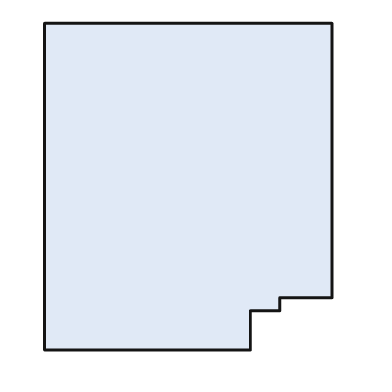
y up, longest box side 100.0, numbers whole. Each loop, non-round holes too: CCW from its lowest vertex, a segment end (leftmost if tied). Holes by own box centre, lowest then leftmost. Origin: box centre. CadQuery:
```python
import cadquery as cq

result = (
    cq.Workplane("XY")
    .moveTo(-44.0, -50.0)
    .lineTo(19.0, -50.0)
    .lineTo(19.0, -38.0)
    .lineTo(28.0, -38.0)
    .lineTo(28.0, -34.0)
    .lineTo(44.0, -34.0)
    .lineTo(44.0, 50.0)
    .lineTo(-44.0, 50.0)
    .close()
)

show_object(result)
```